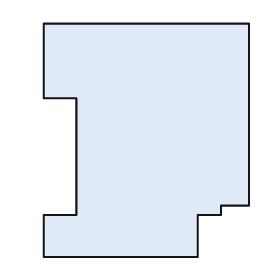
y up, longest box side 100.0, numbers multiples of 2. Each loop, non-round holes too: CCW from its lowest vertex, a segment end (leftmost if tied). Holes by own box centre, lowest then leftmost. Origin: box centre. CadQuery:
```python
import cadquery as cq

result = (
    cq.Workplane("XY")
    .moveTo(-44.0, -50.0)
    .lineTo(22.0, -50.0)
    .lineTo(22.0, -32.0)
    .lineTo(32.0, -32.0)
    .lineTo(32.0, -28.0)
    .lineTo(44.0, -28.0)
    .lineTo(44.0, 50.0)
    .lineTo(-44.0, 50.0)
    .lineTo(-44.0, 18.0)
    .lineTo(-30.0, 18.0)
    .lineTo(-30.0, -32.0)
    .lineTo(-44.0, -32.0)
    .close()
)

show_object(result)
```